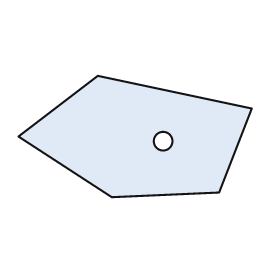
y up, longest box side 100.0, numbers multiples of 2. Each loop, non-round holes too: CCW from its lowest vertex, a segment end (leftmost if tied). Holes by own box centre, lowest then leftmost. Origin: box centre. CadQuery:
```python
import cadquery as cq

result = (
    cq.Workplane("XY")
    .moveTo(-10.0, -26.0)
    .lineTo(36.0, -24.0)
    .lineTo(50.0, 12.0)
    .lineTo(-16.0, 26.0)
    .lineTo(-50.0, 0.0)
    .close()
    .moveTo(12.0, -2.0)
    .circle(4.0)
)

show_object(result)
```